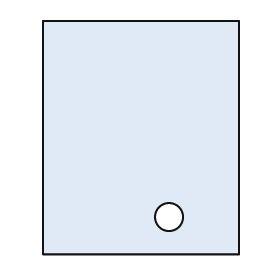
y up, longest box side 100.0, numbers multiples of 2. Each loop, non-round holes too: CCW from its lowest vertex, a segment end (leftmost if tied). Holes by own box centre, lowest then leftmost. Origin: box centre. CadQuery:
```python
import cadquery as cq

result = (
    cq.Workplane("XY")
    .moveTo(-42.0, -50.0)
    .lineTo(42.0, -50.0)
    .lineTo(42.0, 50.0)
    .lineTo(-42.0, 50.0)
    .close()
    .moveTo(12.0, -34.0)
    .circle(6.0)
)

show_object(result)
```